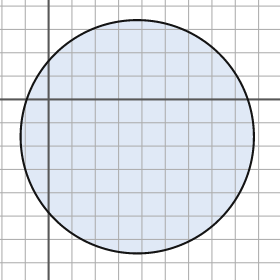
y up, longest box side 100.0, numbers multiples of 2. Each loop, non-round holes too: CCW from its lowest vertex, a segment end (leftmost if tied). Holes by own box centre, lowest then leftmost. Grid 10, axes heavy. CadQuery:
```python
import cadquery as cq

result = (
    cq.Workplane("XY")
    .moveTo(38.0, -16.0)
    .circle(50.0)
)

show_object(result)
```